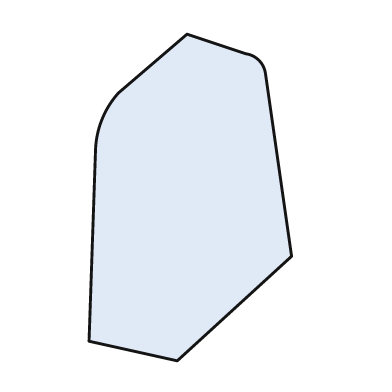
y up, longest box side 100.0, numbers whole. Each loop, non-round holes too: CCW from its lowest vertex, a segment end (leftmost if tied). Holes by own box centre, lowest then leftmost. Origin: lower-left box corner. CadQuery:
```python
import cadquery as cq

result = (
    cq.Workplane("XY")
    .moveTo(27.0, 0.0)
    .lineTo(62.0, 32.0)
    .lineTo(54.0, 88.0)
    .threePointArc((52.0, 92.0), (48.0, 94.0))
    .lineTo(30.0, 100.0)
    .lineTo(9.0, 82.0)
    .threePointArc((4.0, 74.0), (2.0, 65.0))
    .lineTo(0.0, 6.0)
    .close()
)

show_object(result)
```